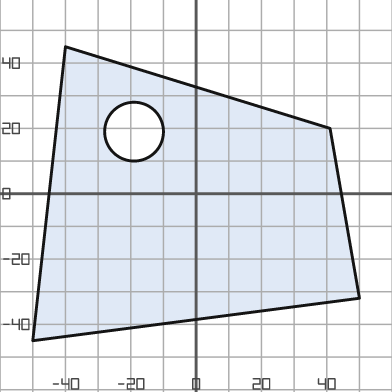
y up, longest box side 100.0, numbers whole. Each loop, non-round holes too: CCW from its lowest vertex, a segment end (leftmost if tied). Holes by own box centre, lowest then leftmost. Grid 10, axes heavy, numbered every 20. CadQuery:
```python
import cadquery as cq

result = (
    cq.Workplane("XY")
    .moveTo(-50.0, -45.0)
    .lineTo(50.0, -32.0)
    .lineTo(41.0, 20.0)
    .lineTo(-40.0, 45.0)
    .close()
    .moveTo(-19.0, 19.0)
    .circle(9.0)
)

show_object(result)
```